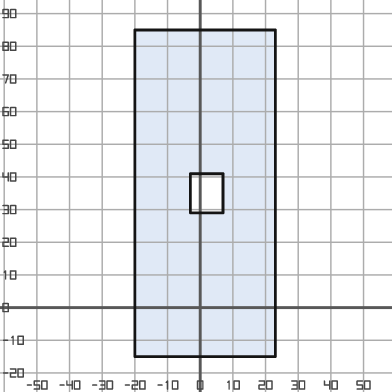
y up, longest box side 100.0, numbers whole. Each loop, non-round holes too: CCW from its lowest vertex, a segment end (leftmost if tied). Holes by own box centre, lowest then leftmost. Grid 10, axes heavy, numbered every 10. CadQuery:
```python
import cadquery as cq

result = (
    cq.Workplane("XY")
    .moveTo(-20.0, -15.0)
    .lineTo(23.0, -15.0)
    .lineTo(23.0, 85.0)
    .lineTo(-20.0, 85.0)
    .close()
    .moveTo(-3.0, 29.0)
    .lineTo(7.0, 29.0)
    .lineTo(7.0, 41.0)
    .lineTo(-3.0, 41.0)
    .close()
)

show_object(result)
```